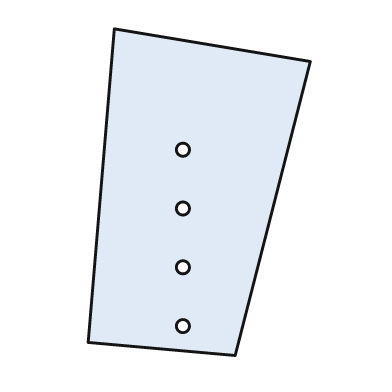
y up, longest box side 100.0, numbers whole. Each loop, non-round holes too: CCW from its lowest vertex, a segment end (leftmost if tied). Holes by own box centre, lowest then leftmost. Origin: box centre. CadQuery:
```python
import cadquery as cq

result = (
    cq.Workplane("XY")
    .moveTo(11.0, -50.0)
    .lineTo(34.0, 40.0)
    .lineTo(-26.0, 50.0)
    .lineTo(-34.0, -46.0)
    .close()
    .moveTo(-5.0, -41.0)
    .circle(2.0)
    .moveTo(-5.0, -23.0)
    .circle(2.0)
    .moveTo(-5.0, -5.0)
    .circle(2.0)
    .moveTo(-5.0, 13.0)
    .circle(2.0)
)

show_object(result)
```